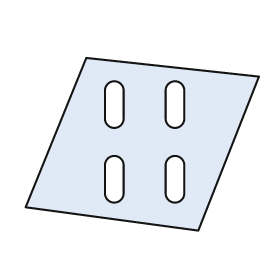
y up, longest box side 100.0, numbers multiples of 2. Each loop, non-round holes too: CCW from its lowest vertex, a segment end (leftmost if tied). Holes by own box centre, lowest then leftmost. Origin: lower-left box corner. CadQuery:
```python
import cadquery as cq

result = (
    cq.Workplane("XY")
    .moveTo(74.0, 0.0)
    .lineTo(100.0, 66.0)
    .lineTo(26.0, 74.0)
    .lineTo(0.0, 10.0)
    .close()
    .moveTo(34.0, 16.0)
    .threePointArc((38.0, 12.0), (42.0, 16.0))
    .lineTo(42.0, 28.0)
    .threePointArc((38.0, 32.0), (34.0, 28.0))
    .close()
    .moveTo(60.0, 16.0)
    .threePointArc((64.0, 12.0), (68.0, 16.0))
    .lineTo(68.0, 28.0)
    .threePointArc((64.0, 32.0), (60.0, 28.0))
    .close()
    .moveTo(34.0, 48.0)
    .threePointArc((38.0, 44.0), (42.0, 48.0))
    .lineTo(42.0, 60.0)
    .threePointArc((38.0, 64.0), (34.0, 60.0))
    .close()
    .moveTo(60.0, 48.0)
    .threePointArc((64.0, 44.0), (68.0, 48.0))
    .lineTo(68.0, 60.0)
    .threePointArc((64.0, 64.0), (60.0, 60.0))
    .close()
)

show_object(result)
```